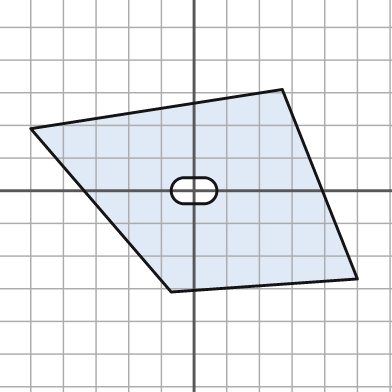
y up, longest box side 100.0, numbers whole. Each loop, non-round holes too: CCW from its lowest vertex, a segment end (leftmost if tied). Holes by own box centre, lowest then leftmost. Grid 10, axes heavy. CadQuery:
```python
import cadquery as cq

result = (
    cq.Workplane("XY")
    .moveTo(-7.0, -31.0)
    .lineTo(50.0, -27.0)
    .lineTo(27.0, 31.0)
    .lineTo(-50.0, 19.0)
    .close()
    .moveTo(-3.0, -4.0)
    .lineTo(3.0, -4.0)
    .threePointArc((7.0, 0.0), (3.0, 4.0))
    .lineTo(-3.0, 4.0)
    .threePointArc((-7.0, 0.0), (-3.0, -4.0))
    .close()
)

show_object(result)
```